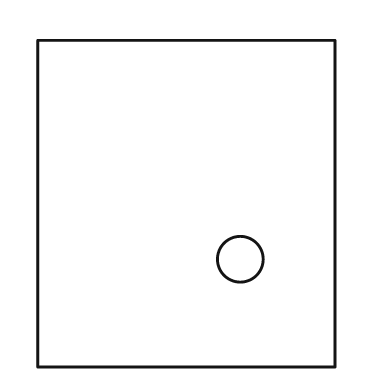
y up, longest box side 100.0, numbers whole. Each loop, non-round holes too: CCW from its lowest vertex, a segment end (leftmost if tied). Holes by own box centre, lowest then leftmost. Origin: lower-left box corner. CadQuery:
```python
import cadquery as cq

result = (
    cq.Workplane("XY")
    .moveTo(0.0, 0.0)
    .lineTo(91.0, 0.0)
    .lineTo(91.0, 100.0)
    .lineTo(0.0, 100.0)
    .close()
    .moveTo(62.0, 33.0)
    .circle(7.0)
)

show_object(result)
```